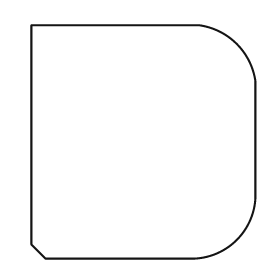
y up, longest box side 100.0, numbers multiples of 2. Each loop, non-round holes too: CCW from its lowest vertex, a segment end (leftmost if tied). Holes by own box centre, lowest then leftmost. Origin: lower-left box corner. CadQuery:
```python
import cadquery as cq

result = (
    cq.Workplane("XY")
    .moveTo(6.0, 0.0)
    .lineTo(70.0, 0.0)
    .threePointArc((88.0, 8.0), (96.0, 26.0))
    .lineTo(96.0, 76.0)
    .threePointArc((88.0, 92.0), (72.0, 100.0))
    .lineTo(0.0, 100.0)
    .lineTo(0.0, 6.0)
    .close()
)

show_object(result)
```